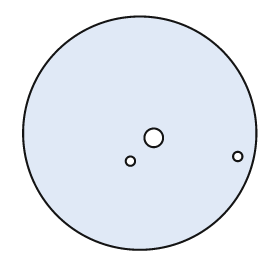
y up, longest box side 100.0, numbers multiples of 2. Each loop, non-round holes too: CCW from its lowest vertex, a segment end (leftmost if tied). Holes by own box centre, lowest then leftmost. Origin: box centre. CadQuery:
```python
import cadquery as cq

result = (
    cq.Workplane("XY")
    .moveTo(0.0, 0.0)
    .circle(50.0)
    .moveTo(-4.0, -12.0)
    .circle(2.0)
    .moveTo(42.0, -10.0)
    .circle(2.0)
    .moveTo(6.0, -2.0)
    .circle(4.0)
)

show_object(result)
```